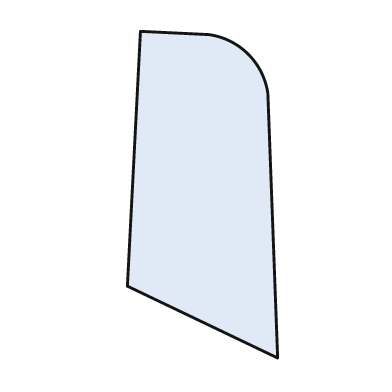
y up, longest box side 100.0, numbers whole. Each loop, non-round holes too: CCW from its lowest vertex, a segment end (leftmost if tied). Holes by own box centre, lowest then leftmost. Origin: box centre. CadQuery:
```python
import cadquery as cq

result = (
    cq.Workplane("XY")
    .moveTo(23.0, -50.0)
    .lineTo(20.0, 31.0)
    .threePointArc((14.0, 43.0), (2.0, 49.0))
    .lineTo(-19.0, 50.0)
    .lineTo(-23.0, -28.0)
    .close()
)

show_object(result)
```